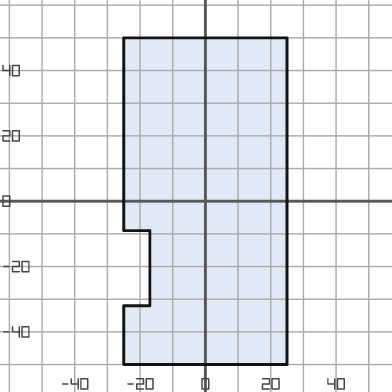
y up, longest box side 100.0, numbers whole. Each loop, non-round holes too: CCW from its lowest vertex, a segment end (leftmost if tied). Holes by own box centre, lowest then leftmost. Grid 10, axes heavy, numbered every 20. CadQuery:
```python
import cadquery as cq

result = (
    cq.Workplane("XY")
    .moveTo(-25.0, -50.0)
    .lineTo(25.0, -50.0)
    .lineTo(25.0, 50.0)
    .lineTo(-25.0, 50.0)
    .lineTo(-25.0, -9.0)
    .lineTo(-17.0, -9.0)
    .lineTo(-17.0, -32.0)
    .lineTo(-25.0, -32.0)
    .close()
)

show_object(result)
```